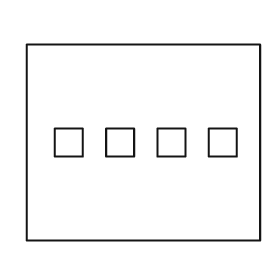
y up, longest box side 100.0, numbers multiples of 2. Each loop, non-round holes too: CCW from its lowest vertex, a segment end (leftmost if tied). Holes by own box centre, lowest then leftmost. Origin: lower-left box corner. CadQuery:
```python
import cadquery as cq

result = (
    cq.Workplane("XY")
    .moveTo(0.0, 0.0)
    .lineTo(100.0, 0.0)
    .lineTo(100.0, 84.0)
    .lineTo(0.0, 84.0)
    .close()
    .moveTo(12.0, 36.0)
    .lineTo(24.0, 36.0)
    .lineTo(24.0, 48.0)
    .lineTo(12.0, 48.0)
    .close()
    .moveTo(34.0, 36.0)
    .lineTo(46.0, 36.0)
    .lineTo(46.0, 48.0)
    .lineTo(34.0, 48.0)
    .close()
    .moveTo(56.0, 36.0)
    .lineTo(68.0, 36.0)
    .lineTo(68.0, 48.0)
    .lineTo(56.0, 48.0)
    .close()
    .moveTo(78.0, 36.0)
    .lineTo(90.0, 36.0)
    .lineTo(90.0, 48.0)
    .lineTo(78.0, 48.0)
    .close()
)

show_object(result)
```